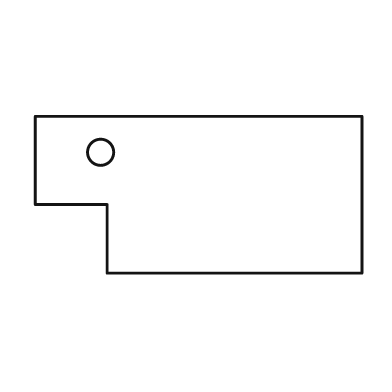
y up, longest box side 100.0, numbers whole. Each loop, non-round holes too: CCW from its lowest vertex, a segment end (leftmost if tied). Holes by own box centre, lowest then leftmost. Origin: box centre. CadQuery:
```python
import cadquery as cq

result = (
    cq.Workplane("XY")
    .moveTo(-28.0, -24.0)
    .lineTo(50.0, -24.0)
    .lineTo(50.0, 24.0)
    .lineTo(-50.0, 24.0)
    .lineTo(-50.0, -3.0)
    .lineTo(-28.0, -3.0)
    .close()
    .moveTo(-30.0, 13.0)
    .circle(4.0)
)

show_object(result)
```